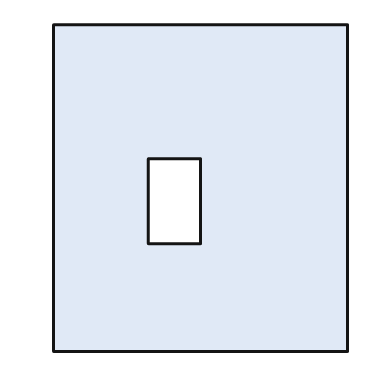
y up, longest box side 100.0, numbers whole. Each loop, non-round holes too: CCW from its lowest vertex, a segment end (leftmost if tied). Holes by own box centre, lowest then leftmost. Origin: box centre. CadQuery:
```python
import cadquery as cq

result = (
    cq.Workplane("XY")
    .moveTo(-45.0, -50.0)
    .lineTo(45.0, -50.0)
    .lineTo(45.0, 50.0)
    .lineTo(-45.0, 50.0)
    .close()
    .moveTo(-16.0, -17.0)
    .lineTo(0.0, -17.0)
    .lineTo(0.0, 9.0)
    .lineTo(-16.0, 9.0)
    .close()
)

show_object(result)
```